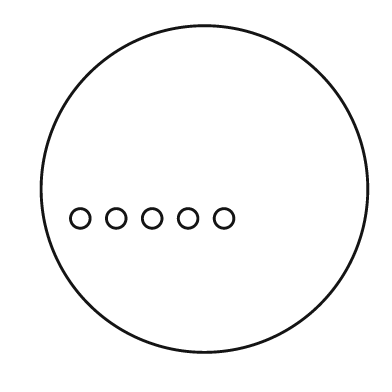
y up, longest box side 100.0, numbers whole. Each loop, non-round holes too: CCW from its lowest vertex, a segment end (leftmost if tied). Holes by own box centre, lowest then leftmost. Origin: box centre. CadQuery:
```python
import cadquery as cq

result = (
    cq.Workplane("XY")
    .moveTo(0.0, 0.0)
    .circle(50.0)
    .moveTo(-38.0, -9.0)
    .circle(3.0)
    .moveTo(-27.0, -9.0)
    .circle(3.0)
    .moveTo(-16.0, -9.0)
    .circle(3.0)
    .moveTo(-5.0, -9.0)
    .circle(3.0)
    .moveTo(6.0, -9.0)
    .circle(3.0)
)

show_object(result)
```